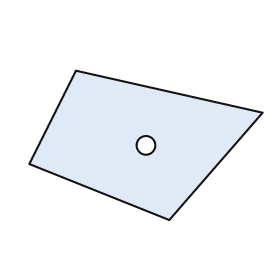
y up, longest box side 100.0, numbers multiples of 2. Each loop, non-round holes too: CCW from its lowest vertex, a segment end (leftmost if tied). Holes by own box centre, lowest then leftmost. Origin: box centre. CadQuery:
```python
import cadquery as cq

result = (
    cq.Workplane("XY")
    .moveTo(10.0, -32.0)
    .lineTo(50.0, 14.0)
    .lineTo(-30.0, 32.0)
    .lineTo(-50.0, -8.0)
    .close()
    .moveTo(0.0, 0.0)
    .circle(4.0)
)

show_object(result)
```